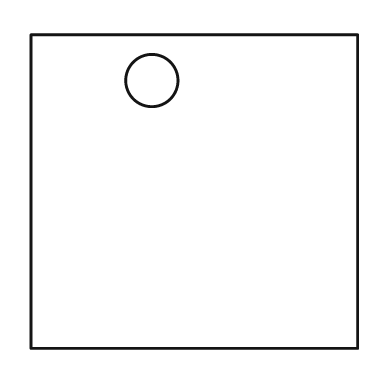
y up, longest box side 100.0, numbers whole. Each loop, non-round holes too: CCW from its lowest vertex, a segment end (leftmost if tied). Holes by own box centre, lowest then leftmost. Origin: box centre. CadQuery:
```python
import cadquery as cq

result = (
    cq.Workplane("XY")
    .moveTo(-50.0, -48.0)
    .lineTo(50.0, -48.0)
    .lineTo(50.0, 48.0)
    .lineTo(-50.0, 48.0)
    .close()
    .moveTo(-13.0, 34.0)
    .circle(8.0)
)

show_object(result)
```